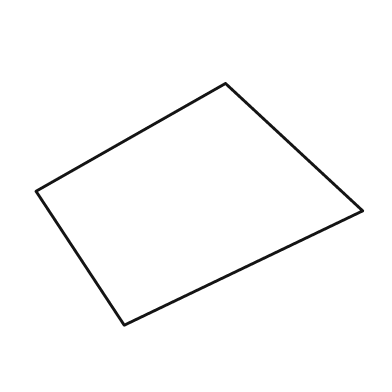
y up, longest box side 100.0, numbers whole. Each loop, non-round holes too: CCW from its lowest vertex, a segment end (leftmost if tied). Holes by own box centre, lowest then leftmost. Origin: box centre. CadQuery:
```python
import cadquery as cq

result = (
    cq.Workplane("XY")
    .moveTo(-23.0, -37.0)
    .lineTo(50.0, -2.0)
    .lineTo(8.0, 37.0)
    .lineTo(-50.0, 4.0)
    .close()
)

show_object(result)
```